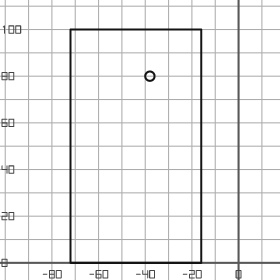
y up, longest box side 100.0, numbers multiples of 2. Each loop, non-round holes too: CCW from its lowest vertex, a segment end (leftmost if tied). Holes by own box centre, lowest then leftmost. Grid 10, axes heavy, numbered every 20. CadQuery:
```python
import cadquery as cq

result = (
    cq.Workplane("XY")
    .moveTo(-72.0, 0.0)
    .lineTo(-16.0, 0.0)
    .lineTo(-16.0, 100.0)
    .lineTo(-72.0, 100.0)
    .close()
    .moveTo(-38.0, 80.0)
    .circle(2.0)
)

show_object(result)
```